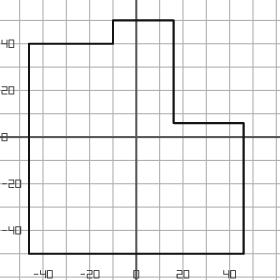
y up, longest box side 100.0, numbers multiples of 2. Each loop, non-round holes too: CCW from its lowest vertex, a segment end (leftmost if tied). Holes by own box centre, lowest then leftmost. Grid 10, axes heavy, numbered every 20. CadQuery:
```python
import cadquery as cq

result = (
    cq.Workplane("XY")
    .moveTo(-46.0, -50.0)
    .lineTo(46.0, -50.0)
    .lineTo(46.0, 6.0)
    .lineTo(16.0, 6.0)
    .lineTo(16.0, 50.0)
    .lineTo(-10.0, 50.0)
    .lineTo(-10.0, 40.0)
    .lineTo(-46.0, 40.0)
    .close()
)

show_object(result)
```